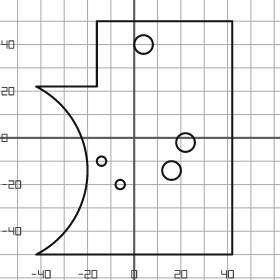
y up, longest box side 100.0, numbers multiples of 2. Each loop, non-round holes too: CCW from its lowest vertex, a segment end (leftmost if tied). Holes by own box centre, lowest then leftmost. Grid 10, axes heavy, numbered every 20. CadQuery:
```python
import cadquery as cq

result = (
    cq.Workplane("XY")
    .moveTo(-42.0, -50.0)
    .lineTo(42.0, -50.0)
    .lineTo(42.0, 50.0)
    .lineTo(-16.0, 50.0)
    .lineTo(-16.0, 22.0)
    .lineTo(-42.0, 22.0)
    .threePointArc((-20.0, -14.0), (-42.0, -50.0))
    .close()
    .moveTo(-6.0, -20.0)
    .circle(2.0)
    .moveTo(16.0, -14.0)
    .circle(4.0)
    .moveTo(-14.0, -10.0)
    .circle(2.0)
    .moveTo(22.0, -2.0)
    .circle(4.0)
    .moveTo(4.0, 40.0)
    .circle(4.0)
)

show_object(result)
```